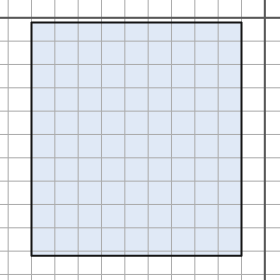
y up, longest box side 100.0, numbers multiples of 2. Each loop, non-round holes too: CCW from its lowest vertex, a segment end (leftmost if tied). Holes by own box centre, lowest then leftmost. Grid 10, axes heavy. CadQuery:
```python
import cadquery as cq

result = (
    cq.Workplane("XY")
    .moveTo(-100.0, -102.0)
    .lineTo(-10.0, -102.0)
    .lineTo(-10.0, -2.0)
    .lineTo(-100.0, -2.0)
    .close()
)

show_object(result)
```